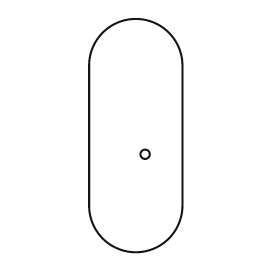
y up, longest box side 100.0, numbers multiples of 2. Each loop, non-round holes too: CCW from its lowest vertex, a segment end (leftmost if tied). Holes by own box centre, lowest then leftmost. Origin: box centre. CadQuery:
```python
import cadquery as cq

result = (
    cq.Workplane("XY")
    .moveTo(-20.0, -30.0)
    .threePointArc((0.0, -50.0), (20.0, -30.0))
    .lineTo(20.0, 30.0)
    .threePointArc((0.0, 50.0), (-20.0, 30.0))
    .close()
    .moveTo(4.0, -8.0)
    .circle(2.0)
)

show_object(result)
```